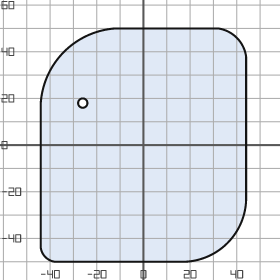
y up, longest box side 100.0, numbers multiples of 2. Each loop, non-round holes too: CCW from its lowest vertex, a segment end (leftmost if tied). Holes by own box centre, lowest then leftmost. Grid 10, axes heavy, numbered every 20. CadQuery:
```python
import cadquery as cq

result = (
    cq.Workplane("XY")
    .moveTo(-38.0, -50.0)
    .lineTo(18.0, -50.0)
    .threePointArc((36.0, -42.0), (44.0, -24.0))
    .lineTo(44.0, 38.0)
    .threePointArc((40.0, 46.0), (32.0, 50.0))
    .lineTo(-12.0, 50.0)
    .threePointArc((-34.0, 40.0), (-44.0, 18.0))
    .lineTo(-44.0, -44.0)
    .threePointArc((-42.0, -48.0), (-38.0, -50.0))
    .close()
    .moveTo(-26.0, 18.0)
    .circle(2.0)
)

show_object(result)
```